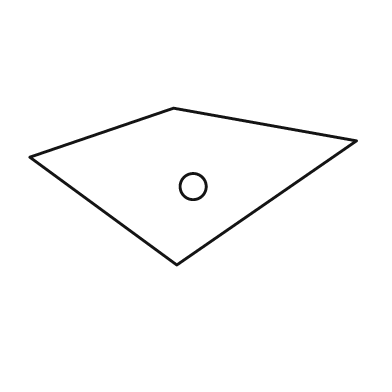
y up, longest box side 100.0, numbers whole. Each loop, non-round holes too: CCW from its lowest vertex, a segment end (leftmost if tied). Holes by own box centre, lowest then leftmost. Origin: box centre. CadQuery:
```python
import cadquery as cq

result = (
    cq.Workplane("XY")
    .moveTo(-5.0, -24.0)
    .lineTo(50.0, 14.0)
    .lineTo(-6.0, 24.0)
    .lineTo(-50.0, 9.0)
    .close()
    .moveTo(0.0, 0.0)
    .circle(4.0)
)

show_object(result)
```